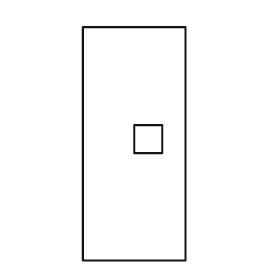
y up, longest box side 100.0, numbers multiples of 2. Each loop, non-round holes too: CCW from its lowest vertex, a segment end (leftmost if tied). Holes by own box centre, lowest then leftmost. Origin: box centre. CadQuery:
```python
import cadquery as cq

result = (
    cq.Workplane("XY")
    .moveTo(-22.0, -50.0)
    .lineTo(22.0, -50.0)
    .lineTo(22.0, 50.0)
    .lineTo(-22.0, 50.0)
    .close()
    .moveTo(0.0, -4.0)
    .lineTo(12.0, -4.0)
    .lineTo(12.0, 8.0)
    .lineTo(0.0, 8.0)
    .close()
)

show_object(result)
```